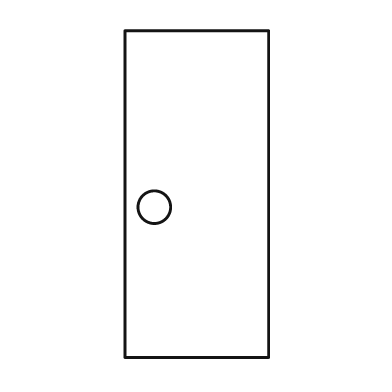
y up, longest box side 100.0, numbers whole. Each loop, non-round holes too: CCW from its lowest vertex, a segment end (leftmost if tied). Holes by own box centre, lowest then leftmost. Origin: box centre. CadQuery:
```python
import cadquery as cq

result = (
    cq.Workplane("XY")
    .moveTo(-22.0, -50.0)
    .lineTo(22.0, -50.0)
    .lineTo(22.0, 50.0)
    .lineTo(-22.0, 50.0)
    .close()
    .moveTo(-13.0, -4.0)
    .circle(5.0)
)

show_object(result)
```